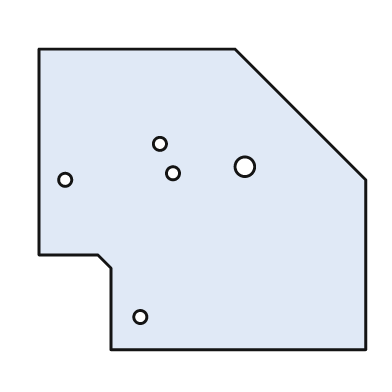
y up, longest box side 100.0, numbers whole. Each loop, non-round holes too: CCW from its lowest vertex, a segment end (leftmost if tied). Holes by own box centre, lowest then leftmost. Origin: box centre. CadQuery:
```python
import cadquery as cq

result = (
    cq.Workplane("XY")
    .moveTo(-28.0, -46.0)
    .lineTo(50.0, -46.0)
    .lineTo(50.0, 6.0)
    .lineTo(10.0, 46.0)
    .lineTo(-50.0, 46.0)
    .lineTo(-50.0, -17.0)
    .lineTo(-32.0, -17.0)
    .lineTo(-28.0, -21.0)
    .close()
    .moveTo(-19.0, -36.0)
    .circle(2.0)
    .moveTo(-42.0, 6.0)
    .circle(2.0)
    .moveTo(-9.0, 8.0)
    .circle(2.0)
    .moveTo(13.0, 10.0)
    .circle(3.0)
    .moveTo(-13.0, 17.0)
    .circle(2.0)
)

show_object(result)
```